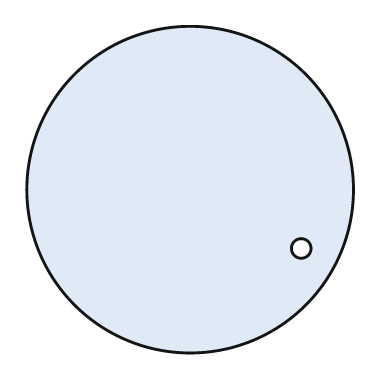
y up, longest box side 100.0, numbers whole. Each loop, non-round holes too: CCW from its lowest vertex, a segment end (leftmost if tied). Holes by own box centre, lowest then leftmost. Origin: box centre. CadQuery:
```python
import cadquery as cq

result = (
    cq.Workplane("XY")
    .moveTo(0.0, 0.0)
    .circle(50.0)
    .moveTo(34.0, -18.0)
    .circle(3.0)
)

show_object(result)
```